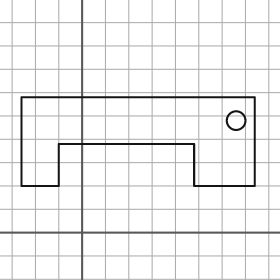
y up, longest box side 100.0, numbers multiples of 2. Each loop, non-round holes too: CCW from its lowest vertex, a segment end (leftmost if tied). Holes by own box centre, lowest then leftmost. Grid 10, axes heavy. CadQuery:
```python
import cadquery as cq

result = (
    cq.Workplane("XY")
    .moveTo(-26.0, 20.0)
    .lineTo(-10.0, 20.0)
    .lineTo(-10.0, 38.0)
    .lineTo(48.0, 38.0)
    .lineTo(48.0, 20.0)
    .lineTo(74.0, 20.0)
    .lineTo(74.0, 58.0)
    .lineTo(-26.0, 58.0)
    .close()
    .moveTo(66.0, 48.0)
    .circle(4.0)
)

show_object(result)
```